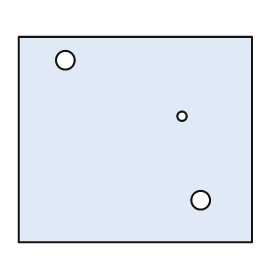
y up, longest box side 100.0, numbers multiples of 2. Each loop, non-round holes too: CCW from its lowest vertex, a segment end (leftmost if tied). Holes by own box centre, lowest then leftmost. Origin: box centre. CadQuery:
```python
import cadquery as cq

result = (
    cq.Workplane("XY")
    .moveTo(-50.0, -44.0)
    .lineTo(50.0, -44.0)
    .lineTo(50.0, 44.0)
    .lineTo(-50.0, 44.0)
    .close()
    .moveTo(28.0, -26.0)
    .circle(4.0)
    .moveTo(20.0, 10.0)
    .circle(2.0)
    .moveTo(-30.0, 34.0)
    .circle(4.0)
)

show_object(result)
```